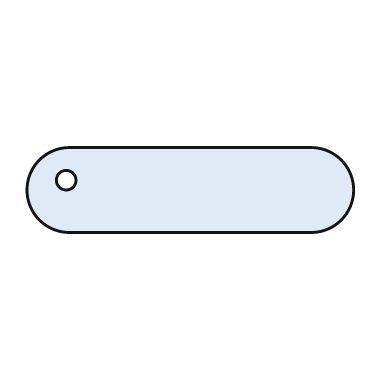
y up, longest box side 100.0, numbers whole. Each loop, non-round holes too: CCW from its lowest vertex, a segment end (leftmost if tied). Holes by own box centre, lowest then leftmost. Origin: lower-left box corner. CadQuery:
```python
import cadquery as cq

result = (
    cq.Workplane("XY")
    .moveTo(13.0, 0.0)
    .lineTo(87.0, 0.0)
    .threePointArc((100.0, 13.0), (87.0, 26.0))
    .lineTo(13.0, 26.0)
    .threePointArc((0.0, 13.0), (13.0, 0.0))
    .close()
    .moveTo(12.0, 16.0)
    .circle(3.0)
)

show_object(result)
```